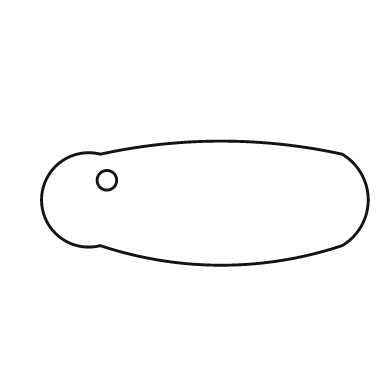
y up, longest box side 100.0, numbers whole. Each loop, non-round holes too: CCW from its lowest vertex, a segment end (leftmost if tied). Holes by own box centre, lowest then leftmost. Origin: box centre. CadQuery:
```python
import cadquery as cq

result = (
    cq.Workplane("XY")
    .moveTo(-32.0, -13.0)
    .threePointArc((5.0, -19.0), (42.0, -13.0))
    .threePointArc((50.0, 1.0), (42.0, 15.0))
    .threePointArc((5.0, 19.0), (-32.0, 15.0))
    .threePointArc((-50.0, 1.0), (-32.0, -13.0))
    .close()
    .moveTo(-30.0, 7.0)
    .circle(3.0)
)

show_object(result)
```